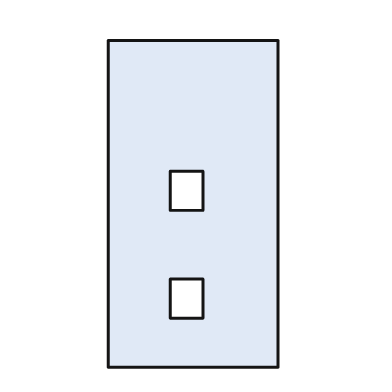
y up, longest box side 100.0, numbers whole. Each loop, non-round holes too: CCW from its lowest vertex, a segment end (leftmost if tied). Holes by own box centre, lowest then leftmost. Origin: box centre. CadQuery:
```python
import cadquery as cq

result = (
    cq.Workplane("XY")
    .moveTo(-26.0, -50.0)
    .lineTo(26.0, -50.0)
    .lineTo(26.0, 50.0)
    .lineTo(-26.0, 50.0)
    .close()
    .moveTo(-7.0, -35.0)
    .lineTo(3.0, -35.0)
    .lineTo(3.0, -23.0)
    .lineTo(-7.0, -23.0)
    .close()
    .moveTo(-7.0, -2.0)
    .lineTo(3.0, -2.0)
    .lineTo(3.0, 10.0)
    .lineTo(-7.0, 10.0)
    .close()
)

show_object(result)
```